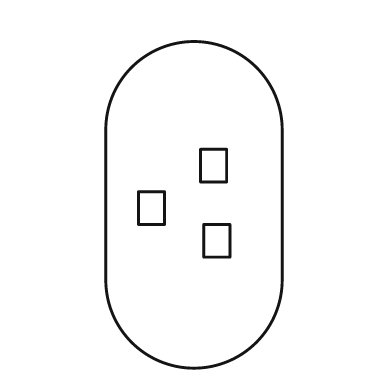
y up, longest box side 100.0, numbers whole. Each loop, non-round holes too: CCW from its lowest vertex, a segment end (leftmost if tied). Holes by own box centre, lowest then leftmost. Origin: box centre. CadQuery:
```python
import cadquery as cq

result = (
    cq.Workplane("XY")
    .moveTo(-27.0, -23.0)
    .threePointArc((0.0, -50.0), (27.0, -23.0))
    .lineTo(27.0, 23.0)
    .threePointArc((0.0, 50.0), (-27.0, 23.0))
    .close()
    .moveTo(3.0, -16.0)
    .lineTo(11.0, -16.0)
    .lineTo(11.0, -6.0)
    .lineTo(3.0, -6.0)
    .close()
    .moveTo(-17.0, -6.0)
    .lineTo(-9.0, -6.0)
    .lineTo(-9.0, 4.0)
    .lineTo(-17.0, 4.0)
    .close()
    .moveTo(2.0, 7.0)
    .lineTo(10.0, 7.0)
    .lineTo(10.0, 17.0)
    .lineTo(2.0, 17.0)
    .close()
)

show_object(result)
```